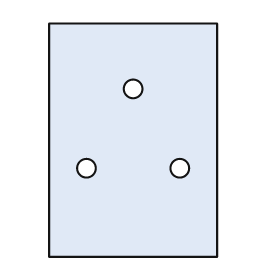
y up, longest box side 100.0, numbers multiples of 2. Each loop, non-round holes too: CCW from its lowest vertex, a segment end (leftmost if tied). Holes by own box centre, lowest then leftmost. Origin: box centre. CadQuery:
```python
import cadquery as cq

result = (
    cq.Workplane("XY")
    .moveTo(-36.0, -50.0)
    .lineTo(36.0, -50.0)
    .lineTo(36.0, 50.0)
    .lineTo(-36.0, 50.0)
    .close()
    .moveTo(-20.0, -12.0)
    .circle(4.0)
    .moveTo(20.0, -12.0)
    .circle(4.0)
    .moveTo(0.0, 22.0)
    .circle(4.0)
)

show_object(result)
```